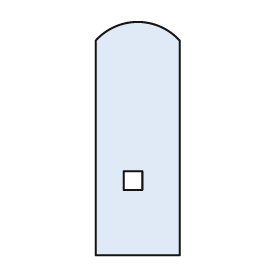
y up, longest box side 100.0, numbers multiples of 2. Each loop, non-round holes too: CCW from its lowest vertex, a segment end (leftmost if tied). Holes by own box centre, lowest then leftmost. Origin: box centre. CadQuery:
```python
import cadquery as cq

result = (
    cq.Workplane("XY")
    .moveTo(-18.0, -50.0)
    .lineTo(18.0, -50.0)
    .lineTo(18.0, 42.0)
    .threePointArc((0.0, 50.0), (-18.0, 42.0))
    .close()
    .moveTo(-6.0, -22.0)
    .lineTo(2.0, -22.0)
    .lineTo(2.0, -14.0)
    .lineTo(-6.0, -14.0)
    .close()
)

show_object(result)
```